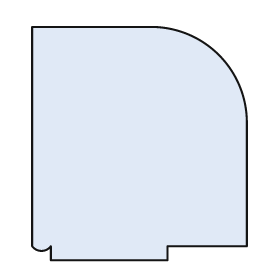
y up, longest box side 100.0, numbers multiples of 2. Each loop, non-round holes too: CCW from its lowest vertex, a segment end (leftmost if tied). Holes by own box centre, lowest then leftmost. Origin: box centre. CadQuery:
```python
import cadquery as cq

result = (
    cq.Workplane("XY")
    .moveTo(-38.0, -50.0)
    .lineTo(12.0, -50.0)
    .lineTo(12.0, -44.0)
    .lineTo(46.0, -44.0)
    .lineTo(46.0, 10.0)
    .threePointArc((34.0, 38.0), (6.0, 50.0))
    .lineTo(-46.0, 50.0)
    .lineTo(-46.0, -44.0)
    .threePointArc((-42.0, -46.0), (-38.0, -44.0))
    .close()
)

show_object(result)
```